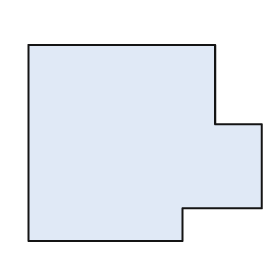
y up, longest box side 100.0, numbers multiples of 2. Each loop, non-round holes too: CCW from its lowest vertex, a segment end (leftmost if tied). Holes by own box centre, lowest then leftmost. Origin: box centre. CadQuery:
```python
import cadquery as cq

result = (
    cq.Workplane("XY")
    .moveTo(-50.0, -42.0)
    .lineTo(16.0, -42.0)
    .lineTo(16.0, -28.0)
    .lineTo(50.0, -28.0)
    .lineTo(50.0, 8.0)
    .lineTo(30.0, 8.0)
    .lineTo(30.0, 42.0)
    .lineTo(-50.0, 42.0)
    .close()
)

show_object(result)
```